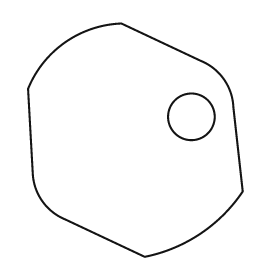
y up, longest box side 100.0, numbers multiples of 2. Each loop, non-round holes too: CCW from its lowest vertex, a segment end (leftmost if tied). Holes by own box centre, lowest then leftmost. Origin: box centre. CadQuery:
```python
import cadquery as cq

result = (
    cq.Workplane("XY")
    .moveTo(4.0, -50.0)
    .threePointArc((28.0, -40.0), (46.0, -22.0))
    .lineTo(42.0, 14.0)
    .threePointArc((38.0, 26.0), (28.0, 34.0))
    .lineTo(-6.0, 50.0)
    .threePointArc((-30.0, 42.0), (-46.0, 22.0))
    .lineTo(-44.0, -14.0)
    .threePointArc((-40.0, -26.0), (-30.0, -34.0))
    .close()
    .moveTo(24.0, 10.0)
    .circle(10.0)
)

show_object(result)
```